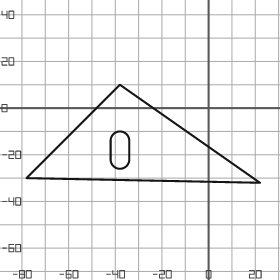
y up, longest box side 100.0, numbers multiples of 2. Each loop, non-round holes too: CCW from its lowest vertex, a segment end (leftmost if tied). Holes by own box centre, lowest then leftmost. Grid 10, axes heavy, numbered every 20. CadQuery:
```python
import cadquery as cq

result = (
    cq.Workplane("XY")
    .moveTo(22.0, -32.0)
    .lineTo(-38.0, 10.0)
    .lineTo(-78.0, -30.0)
    .close()
    .moveTo(-42.0, -22.0)
    .threePointArc((-38.0, -26.0), (-34.0, -22.0))
    .lineTo(-34.0, -14.0)
    .threePointArc((-38.0, -10.0), (-42.0, -14.0))
    .close()
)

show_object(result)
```